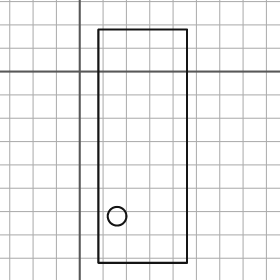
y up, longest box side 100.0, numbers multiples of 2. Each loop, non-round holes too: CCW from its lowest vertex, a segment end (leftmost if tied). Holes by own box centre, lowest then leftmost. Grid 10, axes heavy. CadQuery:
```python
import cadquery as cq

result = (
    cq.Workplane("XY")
    .moveTo(8.0, -82.0)
    .lineTo(46.0, -82.0)
    .lineTo(46.0, 18.0)
    .lineTo(8.0, 18.0)
    .close()
    .moveTo(16.0, -62.0)
    .circle(4.0)
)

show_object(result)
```